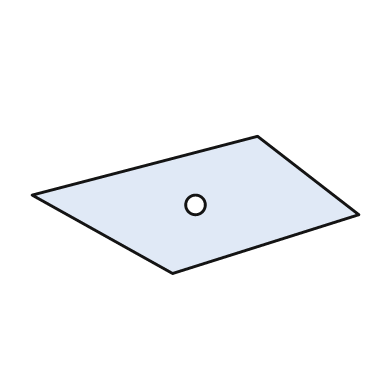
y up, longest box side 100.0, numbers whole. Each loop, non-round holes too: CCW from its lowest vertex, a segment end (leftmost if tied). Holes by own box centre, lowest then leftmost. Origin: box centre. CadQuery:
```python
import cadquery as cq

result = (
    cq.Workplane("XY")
    .moveTo(-7.0, -21.0)
    .lineTo(50.0, -3.0)
    .lineTo(19.0, 21.0)
    .lineTo(-50.0, 3.0)
    .close()
    .moveTo(0.0, 0.0)
    .circle(3.0)
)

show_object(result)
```